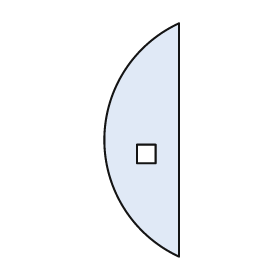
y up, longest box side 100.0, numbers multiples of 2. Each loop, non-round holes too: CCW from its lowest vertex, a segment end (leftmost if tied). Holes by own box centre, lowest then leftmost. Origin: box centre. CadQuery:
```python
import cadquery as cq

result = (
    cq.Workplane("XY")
    .moveTo(16.0, -50.0)
    .lineTo(16.0, 50.0)
    .threePointArc((-16.0, 0.0), (16.0, -50.0))
    .close()
    .moveTo(-2.0, -10.0)
    .lineTo(6.0, -10.0)
    .lineTo(6.0, -2.0)
    .lineTo(-2.0, -2.0)
    .close()
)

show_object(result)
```